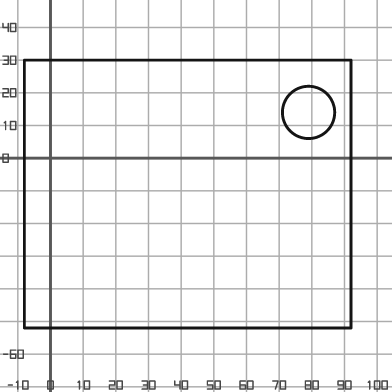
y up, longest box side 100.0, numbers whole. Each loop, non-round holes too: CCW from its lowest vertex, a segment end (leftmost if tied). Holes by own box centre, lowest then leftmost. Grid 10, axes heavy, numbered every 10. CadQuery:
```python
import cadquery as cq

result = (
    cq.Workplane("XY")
    .moveTo(-8.0, -52.0)
    .lineTo(92.0, -52.0)
    .lineTo(92.0, 30.0)
    .lineTo(-8.0, 30.0)
    .close()
    .moveTo(79.0, 14.0)
    .circle(8.0)
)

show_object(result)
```